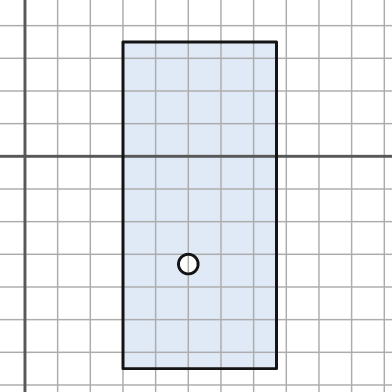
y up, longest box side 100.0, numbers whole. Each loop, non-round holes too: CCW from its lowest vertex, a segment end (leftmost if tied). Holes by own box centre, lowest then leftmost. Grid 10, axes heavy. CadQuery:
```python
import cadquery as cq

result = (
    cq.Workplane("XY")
    .moveTo(30.0, -65.0)
    .lineTo(77.0, -65.0)
    .lineTo(77.0, 35.0)
    .lineTo(30.0, 35.0)
    .close()
    .moveTo(50.0, -33.0)
    .circle(3.0)
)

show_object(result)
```